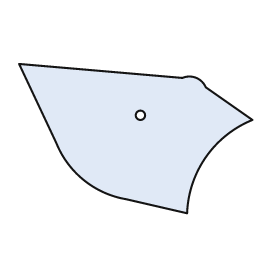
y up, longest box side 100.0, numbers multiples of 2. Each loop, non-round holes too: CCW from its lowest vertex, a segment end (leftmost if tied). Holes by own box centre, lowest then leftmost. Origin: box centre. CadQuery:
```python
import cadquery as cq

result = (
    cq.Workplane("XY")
    .moveTo(22.0, -32.0)
    .threePointArc((30.0, -8.0), (50.0, 8.0))
    .lineTo(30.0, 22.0)
    .threePointArc((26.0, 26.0), (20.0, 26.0))
    .lineTo(-50.0, 32.0)
    .lineTo(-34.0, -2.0)
    .threePointArc((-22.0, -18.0), (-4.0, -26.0))
    .close()
    .moveTo(2.0, 10.0)
    .circle(2.0)
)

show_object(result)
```